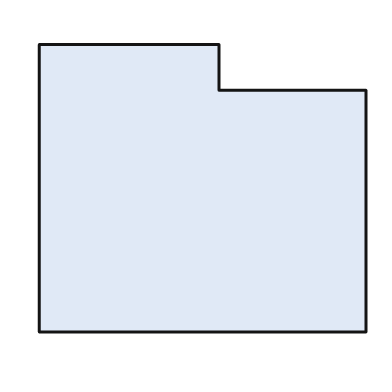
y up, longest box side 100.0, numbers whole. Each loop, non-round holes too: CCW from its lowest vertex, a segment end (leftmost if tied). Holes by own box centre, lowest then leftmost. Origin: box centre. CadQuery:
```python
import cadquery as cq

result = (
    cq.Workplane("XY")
    .moveTo(-50.0, -44.0)
    .lineTo(50.0, -44.0)
    .lineTo(50.0, 30.0)
    .lineTo(5.0, 30.0)
    .lineTo(5.0, 44.0)
    .lineTo(-50.0, 44.0)
    .close()
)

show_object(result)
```